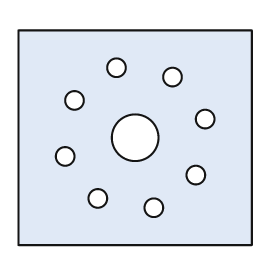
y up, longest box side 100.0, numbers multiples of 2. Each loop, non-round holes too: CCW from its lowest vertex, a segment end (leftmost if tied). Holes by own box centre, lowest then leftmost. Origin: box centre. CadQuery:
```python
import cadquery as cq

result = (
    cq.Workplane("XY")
    .moveTo(-50.0, -46.0)
    .lineTo(50.0, -46.0)
    .lineTo(50.0, 46.0)
    .lineTo(-50.0, 46.0)
    .close()
    .moveTo(8.0, -30.0)
    .circle(4.0)
    .moveTo(-16.0, -26.0)
    .circle(4.0)
    .moveTo(26.0, -16.0)
    .circle(4.0)
    .moveTo(-30.0, -8.0)
    .circle(4.0)
    .moveTo(0.0, 0.0)
    .circle(10.0)
    .moveTo(30.0, 8.0)
    .circle(4.0)
    .moveTo(-26.0, 16.0)
    .circle(4.0)
    .moveTo(16.0, 26.0)
    .circle(4.0)
    .moveTo(-8.0, 30.0)
    .circle(4.0)
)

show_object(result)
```